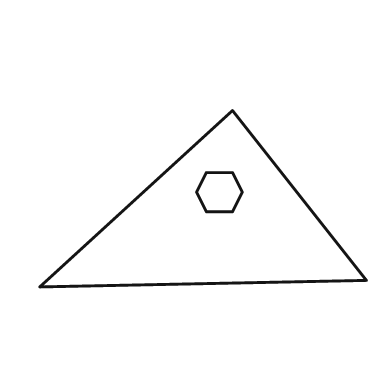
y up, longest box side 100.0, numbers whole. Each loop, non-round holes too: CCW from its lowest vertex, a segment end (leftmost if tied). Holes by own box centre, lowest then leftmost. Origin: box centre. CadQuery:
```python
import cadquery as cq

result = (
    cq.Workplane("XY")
    .moveTo(-50.0, -27.0)
    .lineTo(50.0, -25.0)
    .lineTo(9.0, 27.0)
    .close()
    .moveTo(1.0, -4.0)
    .lineTo(9.0, -4.0)
    .lineTo(12.0, 2.0)
    .lineTo(9.0, 8.0)
    .lineTo(1.0, 8.0)
    .lineTo(-2.0, 2.0)
    .close()
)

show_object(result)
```